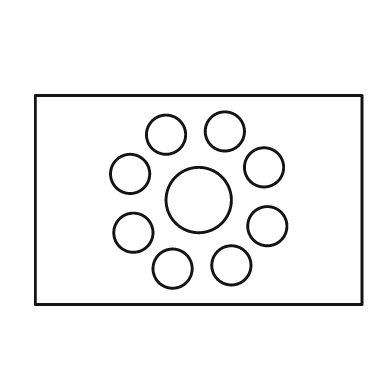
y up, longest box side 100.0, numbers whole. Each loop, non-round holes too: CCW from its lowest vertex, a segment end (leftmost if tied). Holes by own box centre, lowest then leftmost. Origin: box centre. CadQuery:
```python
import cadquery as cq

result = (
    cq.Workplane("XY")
    .moveTo(-50.0, -32.0)
    .lineTo(50.0, -32.0)
    .lineTo(50.0, 32.0)
    .lineTo(-50.0, 32.0)
    .close()
    .moveTo(-8.0, -21.0)
    .circle(6.0)
    .moveTo(10.0, -20.0)
    .circle(6.0)
    .moveTo(-20.0, -10.0)
    .circle(6.0)
    .moveTo(21.0, -8.0)
    .circle(6.0)
    .moveTo(0.0, 0.0)
    .circle(10.0)
    .moveTo(-21.0, 8.0)
    .circle(6.0)
    .moveTo(20.0, 10.0)
    .circle(6.0)
    .moveTo(-10.0, 20.0)
    .circle(6.0)
    .moveTo(8.0, 21.0)
    .circle(6.0)
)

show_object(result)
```